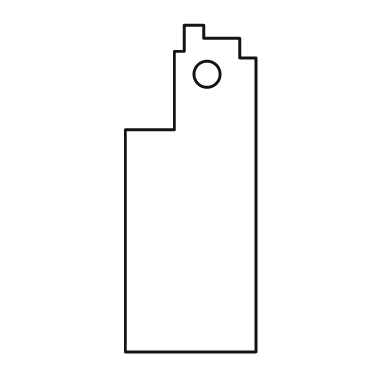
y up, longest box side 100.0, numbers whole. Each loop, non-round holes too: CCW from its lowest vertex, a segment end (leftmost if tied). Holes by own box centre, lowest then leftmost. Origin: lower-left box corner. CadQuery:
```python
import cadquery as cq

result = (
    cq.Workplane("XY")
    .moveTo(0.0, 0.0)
    .lineTo(40.0, 0.0)
    .lineTo(40.0, 90.0)
    .lineTo(35.0, 90.0)
    .lineTo(35.0, 96.0)
    .lineTo(24.0, 96.0)
    .lineTo(24.0, 100.0)
    .lineTo(18.0, 100.0)
    .lineTo(18.0, 92.0)
    .lineTo(15.0, 92.0)
    .lineTo(15.0, 68.0)
    .lineTo(0.0, 68.0)
    .close()
    .moveTo(25.0, 85.0)
    .circle(4.0)
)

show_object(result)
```